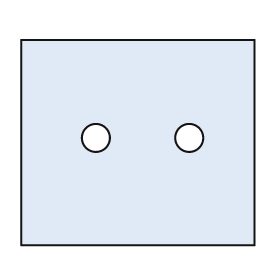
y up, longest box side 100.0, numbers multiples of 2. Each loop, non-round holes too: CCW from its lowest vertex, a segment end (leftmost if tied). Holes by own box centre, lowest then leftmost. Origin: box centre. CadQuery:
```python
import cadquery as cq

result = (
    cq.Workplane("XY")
    .moveTo(-50.0, -44.0)
    .lineTo(50.0, -44.0)
    .lineTo(50.0, 44.0)
    .lineTo(-50.0, 44.0)
    .close()
    .moveTo(-18.0, 2.0)
    .circle(6.0)
    .moveTo(22.0, 2.0)
    .circle(6.0)
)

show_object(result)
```